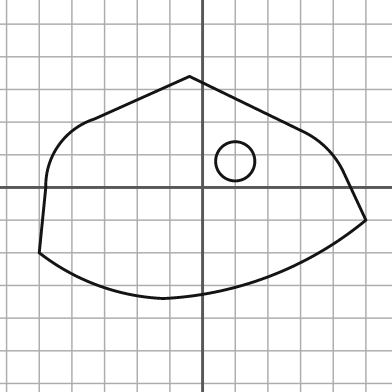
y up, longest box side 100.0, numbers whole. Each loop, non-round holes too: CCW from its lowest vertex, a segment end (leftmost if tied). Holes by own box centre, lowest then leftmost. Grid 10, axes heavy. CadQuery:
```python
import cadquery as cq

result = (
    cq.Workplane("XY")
    .moveTo(-12.0, -34.0)
    .threePointArc((21.0, -27.0), (50.0, -10.0))
    .lineTo(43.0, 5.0)
    .threePointArc((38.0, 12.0), (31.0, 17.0))
    .lineTo(-4.0, 34.0)
    .lineTo(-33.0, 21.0)
    .threePointArc((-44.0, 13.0), (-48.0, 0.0))
    .lineTo(-50.0, -20.0)
    .threePointArc((-32.0, -30.0), (-12.0, -34.0))
    .close()
    .moveTo(10.0, 8.0)
    .circle(6.0)
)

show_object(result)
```